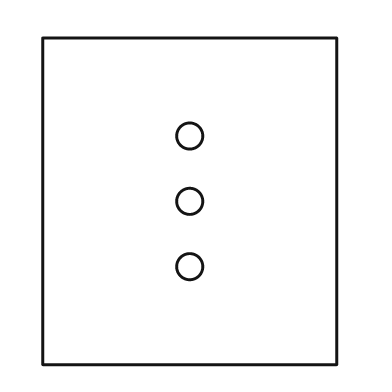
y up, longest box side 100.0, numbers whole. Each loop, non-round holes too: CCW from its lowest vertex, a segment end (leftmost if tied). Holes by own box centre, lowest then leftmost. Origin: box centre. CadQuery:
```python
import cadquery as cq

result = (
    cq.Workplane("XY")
    .moveTo(-45.0, -50.0)
    .lineTo(45.0, -50.0)
    .lineTo(45.0, 50.0)
    .lineTo(-45.0, 50.0)
    .close()
    .moveTo(0.0, -20.0)
    .circle(4.0)
    .moveTo(0.0, 0.0)
    .circle(4.0)
    .moveTo(0.0, 20.0)
    .circle(4.0)
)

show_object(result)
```